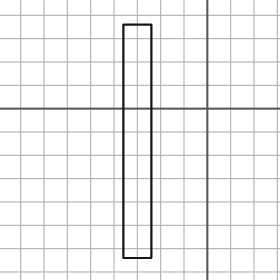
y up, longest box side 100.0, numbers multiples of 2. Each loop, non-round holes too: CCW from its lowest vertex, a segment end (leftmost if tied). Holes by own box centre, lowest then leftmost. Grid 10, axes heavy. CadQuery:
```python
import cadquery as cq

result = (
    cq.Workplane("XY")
    .moveTo(-36.0, -64.0)
    .lineTo(-24.0, -64.0)
    .lineTo(-24.0, 36.0)
    .lineTo(-36.0, 36.0)
    .close()
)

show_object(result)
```